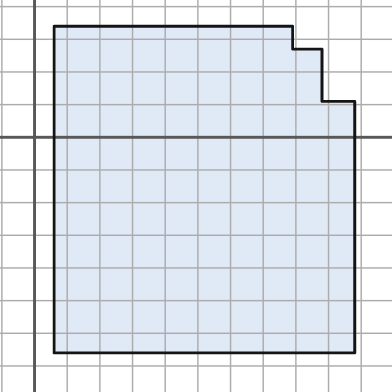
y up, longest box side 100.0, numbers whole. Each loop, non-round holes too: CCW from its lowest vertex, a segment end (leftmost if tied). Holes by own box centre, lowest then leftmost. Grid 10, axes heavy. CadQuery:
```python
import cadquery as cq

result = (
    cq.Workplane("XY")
    .moveTo(6.0, -66.0)
    .lineTo(98.0, -66.0)
    .lineTo(98.0, 11.0)
    .lineTo(88.0, 11.0)
    .lineTo(88.0, 27.0)
    .lineTo(79.0, 27.0)
    .lineTo(79.0, 34.0)
    .lineTo(6.0, 34.0)
    .close()
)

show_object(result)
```